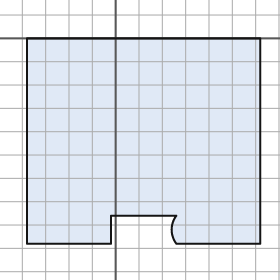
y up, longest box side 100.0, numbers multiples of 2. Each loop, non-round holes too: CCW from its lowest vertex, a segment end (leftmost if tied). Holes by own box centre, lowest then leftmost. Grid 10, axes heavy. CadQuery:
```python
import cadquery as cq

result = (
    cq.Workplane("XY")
    .moveTo(-38.0, -88.0)
    .lineTo(-2.0, -88.0)
    .lineTo(-2.0, -76.0)
    .lineTo(26.0, -76.0)
    .threePointArc((24.0, -82.0), (26.0, -88.0))
    .lineTo(62.0, -88.0)
    .lineTo(62.0, 0.0)
    .lineTo(-38.0, 0.0)
    .close()
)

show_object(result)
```